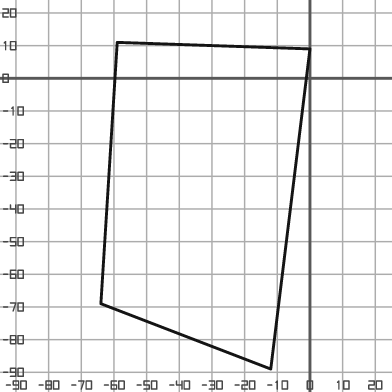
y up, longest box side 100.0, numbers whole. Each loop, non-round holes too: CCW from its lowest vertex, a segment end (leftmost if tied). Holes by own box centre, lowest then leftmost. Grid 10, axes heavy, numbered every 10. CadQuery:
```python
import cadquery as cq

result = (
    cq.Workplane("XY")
    .moveTo(-12.0, -89.0)
    .lineTo(0.0, 9.0)
    .lineTo(-59.0, 11.0)
    .lineTo(-64.0, -69.0)
    .close()
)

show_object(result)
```